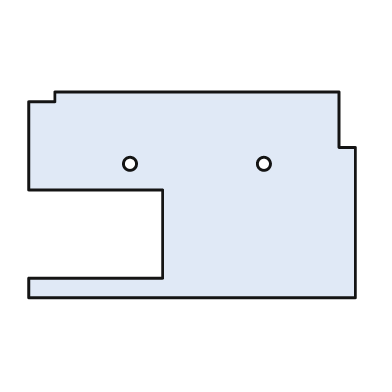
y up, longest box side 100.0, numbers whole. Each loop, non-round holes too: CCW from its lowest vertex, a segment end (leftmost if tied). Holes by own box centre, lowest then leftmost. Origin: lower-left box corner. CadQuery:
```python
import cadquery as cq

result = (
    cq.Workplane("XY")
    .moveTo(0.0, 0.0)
    .lineTo(100.0, 0.0)
    .lineTo(100.0, 46.0)
    .lineTo(95.0, 46.0)
    .lineTo(95.0, 63.0)
    .lineTo(8.0, 63.0)
    .lineTo(8.0, 60.0)
    .lineTo(0.0, 60.0)
    .lineTo(0.0, 33.0)
    .lineTo(41.0, 33.0)
    .lineTo(41.0, 6.0)
    .lineTo(0.0, 6.0)
    .close()
    .moveTo(31.0, 41.0)
    .circle(2.0)
    .moveTo(72.0, 41.0)
    .circle(2.0)
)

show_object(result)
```